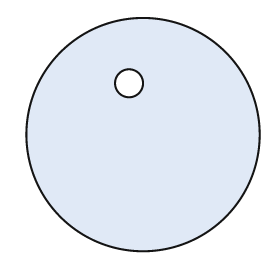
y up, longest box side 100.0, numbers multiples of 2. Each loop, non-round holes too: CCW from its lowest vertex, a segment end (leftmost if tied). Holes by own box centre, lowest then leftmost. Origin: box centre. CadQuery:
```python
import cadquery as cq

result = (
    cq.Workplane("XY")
    .moveTo(0.0, 0.0)
    .circle(50.0)
    .moveTo(-6.0, 22.0)
    .circle(6.0)
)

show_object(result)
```